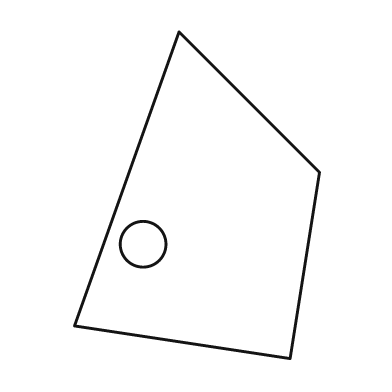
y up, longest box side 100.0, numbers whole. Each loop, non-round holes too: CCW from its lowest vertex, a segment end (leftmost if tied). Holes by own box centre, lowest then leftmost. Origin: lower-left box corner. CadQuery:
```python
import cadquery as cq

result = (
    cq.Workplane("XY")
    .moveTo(66.0, 0.0)
    .lineTo(75.0, 57.0)
    .lineTo(32.0, 100.0)
    .lineTo(0.0, 10.0)
    .close()
    .moveTo(21.0, 35.0)
    .circle(7.0)
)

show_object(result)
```